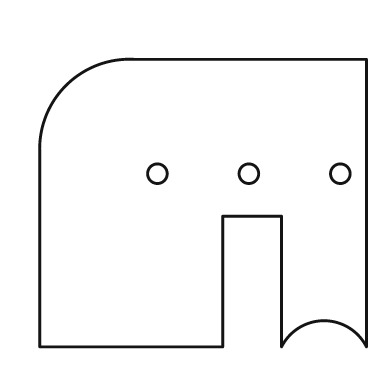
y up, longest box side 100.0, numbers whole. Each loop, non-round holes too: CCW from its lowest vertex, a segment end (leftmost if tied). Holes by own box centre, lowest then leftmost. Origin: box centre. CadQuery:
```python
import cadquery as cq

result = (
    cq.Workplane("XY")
    .moveTo(-50.0, -44.0)
    .lineTo(6.0, -44.0)
    .lineTo(6.0, -4.0)
    .lineTo(24.0, -4.0)
    .lineTo(24.0, -44.0)
    .threePointArc((37.0, -36.0), (50.0, -44.0))
    .lineTo(50.0, 44.0)
    .lineTo(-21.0, 44.0)
    .threePointArc((-42.0, 36.0), (-50.0, 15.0))
    .close()
    .moveTo(-14.0, 9.0)
    .circle(3.0)
    .moveTo(14.0, 9.0)
    .circle(3.0)
    .moveTo(42.0, 9.0)
    .circle(3.0)
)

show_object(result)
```